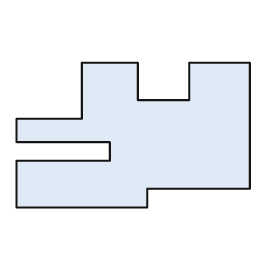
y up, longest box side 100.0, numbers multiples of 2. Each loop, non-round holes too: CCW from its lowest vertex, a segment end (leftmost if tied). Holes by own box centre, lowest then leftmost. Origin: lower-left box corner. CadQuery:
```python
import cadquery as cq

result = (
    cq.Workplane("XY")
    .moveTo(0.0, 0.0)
    .lineTo(56.0, 0.0)
    .lineTo(56.0, 8.0)
    .lineTo(100.0, 8.0)
    .lineTo(100.0, 62.0)
    .lineTo(74.0, 62.0)
    .lineTo(74.0, 46.0)
    .lineTo(52.0, 46.0)
    .lineTo(52.0, 62.0)
    .lineTo(28.0, 62.0)
    .lineTo(28.0, 38.0)
    .lineTo(0.0, 38.0)
    .lineTo(0.0, 28.0)
    .lineTo(40.0, 28.0)
    .lineTo(40.0, 20.0)
    .lineTo(0.0, 20.0)
    .close()
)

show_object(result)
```